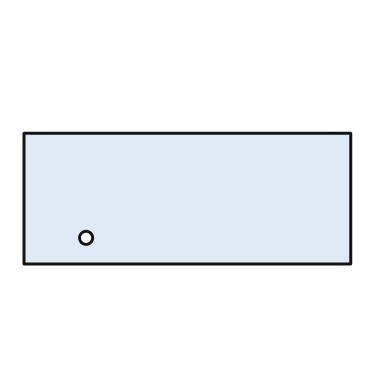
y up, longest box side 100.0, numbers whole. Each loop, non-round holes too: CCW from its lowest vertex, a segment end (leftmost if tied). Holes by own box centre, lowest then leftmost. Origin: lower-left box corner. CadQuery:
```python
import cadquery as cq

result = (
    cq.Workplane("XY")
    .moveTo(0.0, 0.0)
    .lineTo(100.0, 0.0)
    .lineTo(100.0, 40.0)
    .lineTo(0.0, 40.0)
    .close()
    .moveTo(19.0, 8.0)
    .circle(2.0)
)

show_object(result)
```